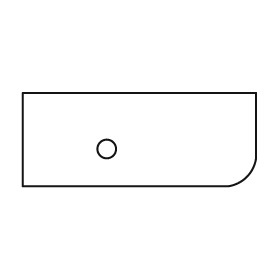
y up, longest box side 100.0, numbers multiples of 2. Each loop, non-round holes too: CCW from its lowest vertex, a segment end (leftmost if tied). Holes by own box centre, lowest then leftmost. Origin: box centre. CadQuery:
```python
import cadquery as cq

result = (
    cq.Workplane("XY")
    .moveTo(-50.0, -20.0)
    .lineTo(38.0, -20.0)
    .threePointArc((46.0, -16.0), (50.0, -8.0))
    .lineTo(50.0, 20.0)
    .lineTo(-50.0, 20.0)
    .close()
    .moveTo(-14.0, -4.0)
    .circle(4.0)
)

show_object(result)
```